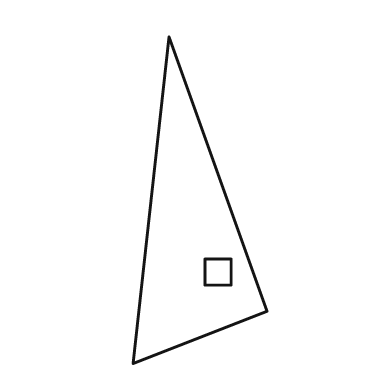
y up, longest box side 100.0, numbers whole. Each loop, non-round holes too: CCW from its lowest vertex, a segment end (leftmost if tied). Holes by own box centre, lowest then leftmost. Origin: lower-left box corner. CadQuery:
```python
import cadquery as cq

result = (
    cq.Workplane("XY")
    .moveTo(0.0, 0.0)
    .lineTo(41.0, 16.0)
    .lineTo(11.0, 100.0)
    .close()
    .moveTo(22.0, 24.0)
    .lineTo(30.0, 24.0)
    .lineTo(30.0, 32.0)
    .lineTo(22.0, 32.0)
    .close()
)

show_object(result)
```